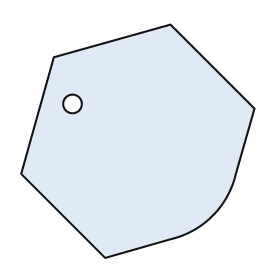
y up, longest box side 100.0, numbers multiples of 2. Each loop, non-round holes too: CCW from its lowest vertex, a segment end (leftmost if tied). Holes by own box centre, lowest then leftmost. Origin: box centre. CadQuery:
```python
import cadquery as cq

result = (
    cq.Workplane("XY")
    .moveTo(-14.0, -50.0)
    .lineTo(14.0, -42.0)
    .threePointArc((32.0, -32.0), (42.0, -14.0))
    .lineTo(50.0, 14.0)
    .lineTo(14.0, 50.0)
    .lineTo(-36.0, 36.0)
    .lineTo(-50.0, -14.0)
    .close()
    .moveTo(-28.0, 16.0)
    .circle(4.0)
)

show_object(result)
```